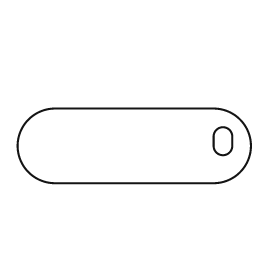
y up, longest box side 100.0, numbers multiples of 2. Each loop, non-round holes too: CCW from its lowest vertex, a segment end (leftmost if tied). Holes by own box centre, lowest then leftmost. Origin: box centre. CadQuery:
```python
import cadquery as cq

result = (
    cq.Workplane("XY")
    .moveTo(-34.0, -16.0)
    .lineTo(34.0, -16.0)
    .threePointArc((50.0, 0.0), (34.0, 16.0))
    .lineTo(-34.0, 16.0)
    .threePointArc((-50.0, 0.0), (-34.0, -16.0))
    .close()
    .moveTo(34.0, 0.0)
    .threePointArc((38.0, -4.0), (42.0, 0.0))
    .lineTo(42.0, 4.0)
    .threePointArc((38.0, 8.0), (34.0, 4.0))
    .close()
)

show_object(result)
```